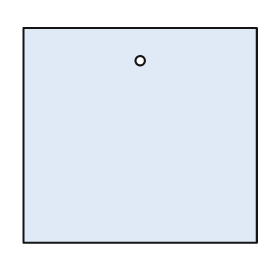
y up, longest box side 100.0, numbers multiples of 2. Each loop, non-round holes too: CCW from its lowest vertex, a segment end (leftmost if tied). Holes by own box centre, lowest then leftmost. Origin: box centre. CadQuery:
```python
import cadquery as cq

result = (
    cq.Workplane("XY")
    .moveTo(-50.0, -46.0)
    .lineTo(50.0, -46.0)
    .lineTo(50.0, 46.0)
    .lineTo(-50.0, 46.0)
    .close()
    .moveTo(0.0, 32.0)
    .circle(2.0)
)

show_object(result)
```